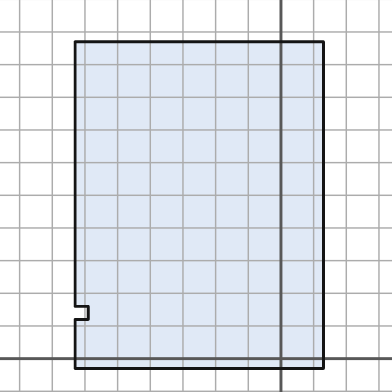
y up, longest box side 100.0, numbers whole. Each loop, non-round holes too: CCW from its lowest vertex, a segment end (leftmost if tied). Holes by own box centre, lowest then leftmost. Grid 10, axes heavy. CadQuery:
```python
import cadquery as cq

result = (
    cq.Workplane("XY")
    .moveTo(-63.0, -3.0)
    .lineTo(13.0, -3.0)
    .lineTo(13.0, 97.0)
    .lineTo(-63.0, 97.0)
    .lineTo(-63.0, 16.0)
    .lineTo(-59.0, 16.0)
    .lineTo(-59.0, 12.0)
    .lineTo(-63.0, 12.0)
    .close()
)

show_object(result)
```